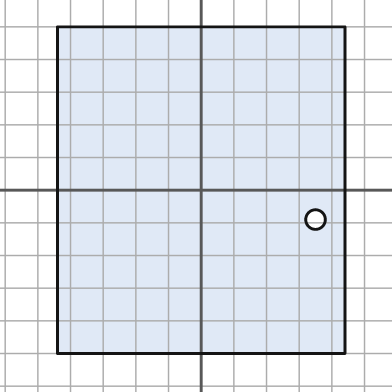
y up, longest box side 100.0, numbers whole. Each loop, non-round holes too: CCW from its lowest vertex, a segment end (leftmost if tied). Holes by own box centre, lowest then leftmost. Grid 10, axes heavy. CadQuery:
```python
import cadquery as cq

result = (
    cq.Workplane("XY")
    .moveTo(-44.0, -50.0)
    .lineTo(44.0, -50.0)
    .lineTo(44.0, 50.0)
    .lineTo(-44.0, 50.0)
    .close()
    .moveTo(35.0, -9.0)
    .circle(3.0)
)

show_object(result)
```